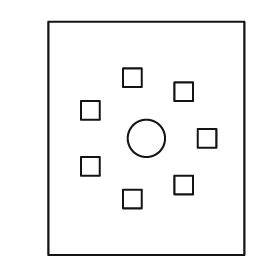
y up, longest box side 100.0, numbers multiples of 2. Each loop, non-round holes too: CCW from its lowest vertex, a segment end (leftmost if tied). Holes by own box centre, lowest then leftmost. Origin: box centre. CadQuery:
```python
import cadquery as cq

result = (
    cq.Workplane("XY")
    .moveTo(-42.0, -50.0)
    .lineTo(42.0, -50.0)
    .lineTo(42.0, 50.0)
    .lineTo(-42.0, 50.0)
    .close()
    .moveTo(-10.0, -30.0)
    .lineTo(-2.0, -30.0)
    .lineTo(-2.0, -22.0)
    .lineTo(-10.0, -22.0)
    .close()
    .moveTo(12.0, -24.0)
    .lineTo(20.0, -24.0)
    .lineTo(20.0, -16.0)
    .lineTo(12.0, -16.0)
    .close()
    .moveTo(-28.0, -16.0)
    .lineTo(-20.0, -16.0)
    .lineTo(-20.0, -8.0)
    .lineTo(-28.0, -8.0)
    .close()
    .moveTo(0.0, 0.0)
    .circle(8.0)
    .moveTo(22.0, -4.0)
    .lineTo(30.0, -4.0)
    .lineTo(30.0, 4.0)
    .lineTo(22.0, 4.0)
    .close()
    .moveTo(-28.0, 8.0)
    .lineTo(-20.0, 8.0)
    .lineTo(-20.0, 16.0)
    .lineTo(-28.0, 16.0)
    .close()
    .moveTo(12.0, 16.0)
    .lineTo(20.0, 16.0)
    .lineTo(20.0, 24.0)
    .lineTo(12.0, 24.0)
    .close()
    .moveTo(-10.0, 22.0)
    .lineTo(-2.0, 22.0)
    .lineTo(-2.0, 30.0)
    .lineTo(-10.0, 30.0)
    .close()
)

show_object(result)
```